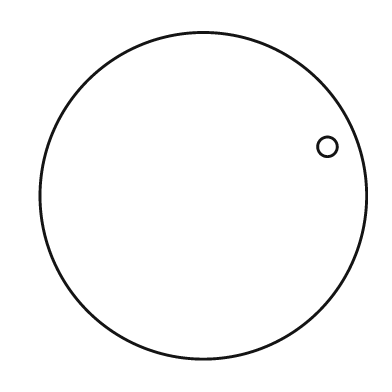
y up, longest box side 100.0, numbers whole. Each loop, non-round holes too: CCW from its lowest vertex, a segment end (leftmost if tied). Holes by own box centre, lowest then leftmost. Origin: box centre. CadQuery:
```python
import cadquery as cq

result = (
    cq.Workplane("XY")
    .moveTo(0.0, 0.0)
    .circle(50.0)
    .moveTo(38.0, 15.0)
    .circle(3.0)
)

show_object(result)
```